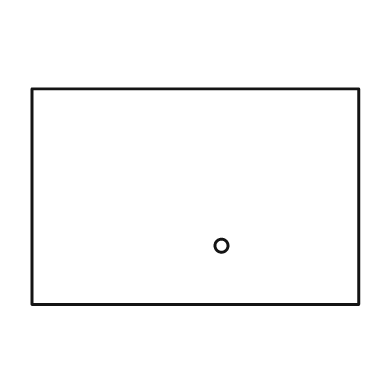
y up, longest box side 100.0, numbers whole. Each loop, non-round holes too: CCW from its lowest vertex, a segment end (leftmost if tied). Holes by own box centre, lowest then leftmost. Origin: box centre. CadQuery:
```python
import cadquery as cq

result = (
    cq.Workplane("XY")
    .moveTo(-50.0, -33.0)
    .lineTo(50.0, -33.0)
    .lineTo(50.0, 33.0)
    .lineTo(-50.0, 33.0)
    .close()
    .moveTo(8.0, -15.0)
    .circle(2.0)
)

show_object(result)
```